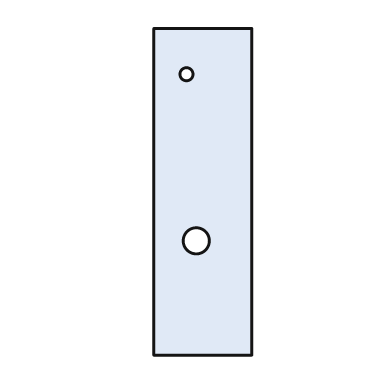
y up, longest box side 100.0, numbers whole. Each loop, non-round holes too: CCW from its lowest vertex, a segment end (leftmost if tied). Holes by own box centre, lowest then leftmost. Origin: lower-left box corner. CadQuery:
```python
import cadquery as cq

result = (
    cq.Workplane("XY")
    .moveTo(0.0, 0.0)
    .lineTo(30.0, 0.0)
    .lineTo(30.0, 100.0)
    .lineTo(0.0, 100.0)
    .close()
    .moveTo(13.0, 35.0)
    .circle(4.0)
    .moveTo(10.0, 86.0)
    .circle(2.0)
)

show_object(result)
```